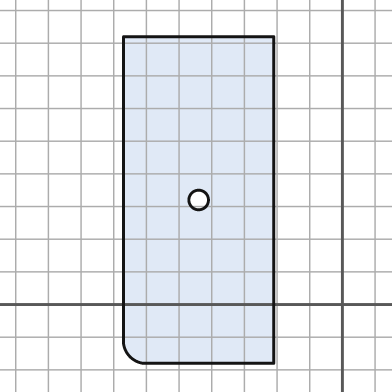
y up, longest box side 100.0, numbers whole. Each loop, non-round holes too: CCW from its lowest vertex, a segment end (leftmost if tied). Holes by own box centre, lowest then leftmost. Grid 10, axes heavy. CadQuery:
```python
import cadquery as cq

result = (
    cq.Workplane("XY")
    .moveTo(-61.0, -18.0)
    .lineTo(-21.0, -18.0)
    .lineTo(-21.0, 82.0)
    .lineTo(-67.0, 82.0)
    .lineTo(-67.0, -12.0)
    .threePointArc((-65.0, -16.0), (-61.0, -18.0))
    .close()
    .moveTo(-44.0, 32.0)
    .circle(3.0)
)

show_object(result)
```